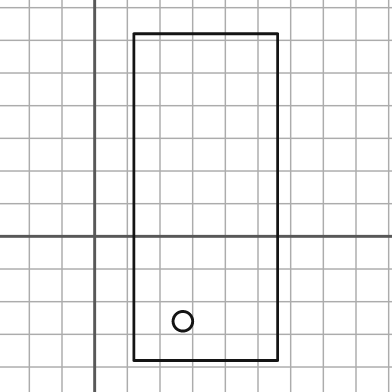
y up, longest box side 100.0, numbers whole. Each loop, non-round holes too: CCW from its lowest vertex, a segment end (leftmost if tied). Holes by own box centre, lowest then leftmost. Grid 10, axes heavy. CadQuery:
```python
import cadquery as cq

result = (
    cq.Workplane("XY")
    .moveTo(12.0, -38.0)
    .lineTo(56.0, -38.0)
    .lineTo(56.0, 62.0)
    .lineTo(12.0, 62.0)
    .close()
    .moveTo(27.0, -26.0)
    .circle(3.0)
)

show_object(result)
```